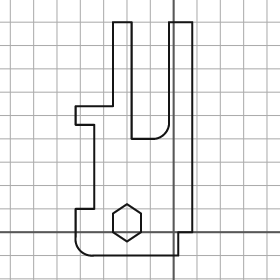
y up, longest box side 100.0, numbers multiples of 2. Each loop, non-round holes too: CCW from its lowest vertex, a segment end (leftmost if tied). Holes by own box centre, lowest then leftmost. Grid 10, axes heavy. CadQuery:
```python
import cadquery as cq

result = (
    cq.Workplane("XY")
    .moveTo(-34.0, -10.0)
    .lineTo(2.0, -10.0)
    .lineTo(2.0, 0.0)
    .lineTo(8.0, 0.0)
    .lineTo(8.0, 90.0)
    .lineTo(-2.0, 90.0)
    .lineTo(-2.0, 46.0)
    .threePointArc((-4.0, 42.0), (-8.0, 40.0))
    .lineTo(-18.0, 40.0)
    .lineTo(-18.0, 90.0)
    .lineTo(-26.0, 90.0)
    .lineTo(-26.0, 54.0)
    .lineTo(-42.0, 54.0)
    .lineTo(-42.0, 46.0)
    .lineTo(-34.0, 46.0)
    .lineTo(-34.0, 10.0)
    .lineTo(-42.0, 10.0)
    .lineTo(-42.0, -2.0)
    .threePointArc((-40.0, -8.0), (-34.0, -10.0))
    .close()
    .moveTo(-20.0, -4.0)
    .lineTo(-14.0, 0.0)
    .lineTo(-14.0, 8.0)
    .lineTo(-20.0, 12.0)
    .lineTo(-26.0, 8.0)
    .lineTo(-26.0, 0.0)
    .close()
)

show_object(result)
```